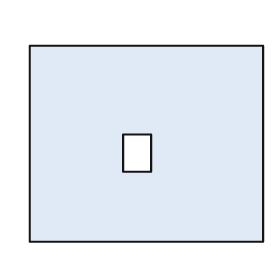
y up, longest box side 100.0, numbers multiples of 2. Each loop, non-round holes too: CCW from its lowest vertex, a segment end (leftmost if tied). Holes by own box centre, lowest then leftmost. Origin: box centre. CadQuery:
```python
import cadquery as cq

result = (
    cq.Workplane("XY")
    .moveTo(-50.0, -42.0)
    .lineTo(50.0, -42.0)
    .lineTo(50.0, 42.0)
    .lineTo(-50.0, 42.0)
    .close()
    .moveTo(-10.0, -12.0)
    .lineTo(2.0, -12.0)
    .lineTo(2.0, 4.0)
    .lineTo(-10.0, 4.0)
    .close()
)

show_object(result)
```